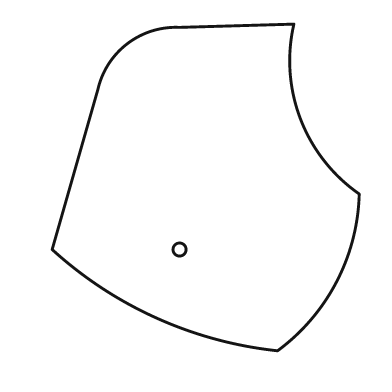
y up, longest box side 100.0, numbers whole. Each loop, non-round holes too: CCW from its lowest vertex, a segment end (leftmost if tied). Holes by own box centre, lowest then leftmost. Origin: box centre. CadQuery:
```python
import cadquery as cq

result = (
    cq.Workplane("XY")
    .moveTo(22.0, -50.0)
    .threePointArc((40.0, -29.0), (47.0, -2.0))
    .threePointArc((29.0, 21.0), (27.0, 50.0))
    .lineTo(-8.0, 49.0)
    .threePointArc((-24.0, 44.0), (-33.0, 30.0))
    .lineTo(-47.0, -19.0)
    .threePointArc((-15.0, -40.0), (22.0, -50.0))
    .close()
    .moveTo(-8.0, -19.0)
    .circle(2.0)
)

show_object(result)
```